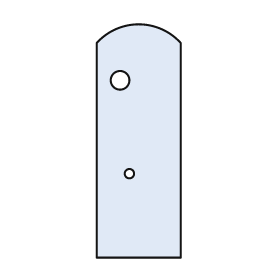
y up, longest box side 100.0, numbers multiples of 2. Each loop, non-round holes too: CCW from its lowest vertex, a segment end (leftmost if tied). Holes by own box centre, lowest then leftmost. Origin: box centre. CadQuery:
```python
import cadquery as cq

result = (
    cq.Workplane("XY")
    .moveTo(-18.0, -50.0)
    .lineTo(18.0, -50.0)
    .lineTo(18.0, 42.0)
    .threePointArc((0.0, 50.0), (-18.0, 42.0))
    .close()
    .moveTo(-4.0, -14.0)
    .circle(2.0)
    .moveTo(-8.0, 26.0)
    .circle(4.0)
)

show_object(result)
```